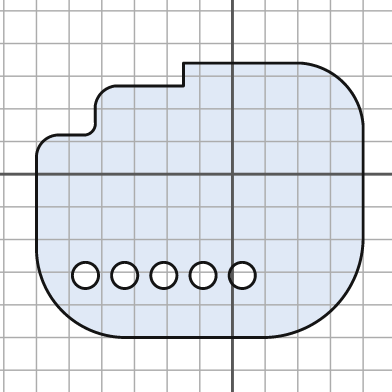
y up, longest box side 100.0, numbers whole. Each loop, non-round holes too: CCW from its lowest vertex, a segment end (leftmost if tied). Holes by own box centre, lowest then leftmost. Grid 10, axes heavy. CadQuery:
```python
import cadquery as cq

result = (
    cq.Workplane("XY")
    .moveTo(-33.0, -50.0)
    .lineTo(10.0, -50.0)
    .threePointArc((31.0, -41.0), (40.0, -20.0))
    .lineTo(40.0, 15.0)
    .threePointArc((34.0, 28.0), (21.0, 34.0))
    .lineTo(-15.0, 34.0)
    .lineTo(-15.0, 27.0)
    .lineTo(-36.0, 27.0)
    .threePointArc((-40.0, 25.0), (-42.0, 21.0))
    .lineTo(-42.0, 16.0)
    .threePointArc((-43.0, 13.0), (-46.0, 12.0))
    .lineTo(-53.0, 12.0)
    .threePointArc((-58.0, 10.0), (-60.0, 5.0))
    .lineTo(-60.0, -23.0)
    .threePointArc((-52.0, -42.0), (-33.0, -50.0))
    .close()
    .moveTo(-45.0, -31.0)
    .circle(4.0)
    .moveTo(-33.0, -31.0)
    .circle(4.0)
    .moveTo(-21.0, -31.0)
    .circle(4.0)
    .moveTo(-9.0, -31.0)
    .circle(4.0)
    .moveTo(3.0, -31.0)
    .circle(4.0)
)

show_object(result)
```